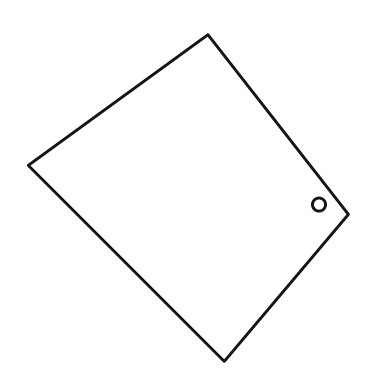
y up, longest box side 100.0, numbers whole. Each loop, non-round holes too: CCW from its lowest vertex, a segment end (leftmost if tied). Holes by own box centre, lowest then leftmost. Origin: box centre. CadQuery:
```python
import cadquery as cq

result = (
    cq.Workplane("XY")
    .moveTo(11.0, -50.0)
    .lineTo(49.0, -5.0)
    .lineTo(6.0, 50.0)
    .lineTo(-49.0, 10.0)
    .close()
    .moveTo(40.0, -2.0)
    .circle(2.0)
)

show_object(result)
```